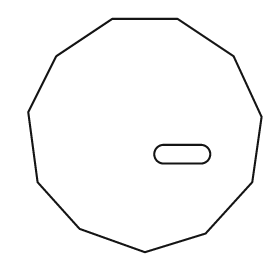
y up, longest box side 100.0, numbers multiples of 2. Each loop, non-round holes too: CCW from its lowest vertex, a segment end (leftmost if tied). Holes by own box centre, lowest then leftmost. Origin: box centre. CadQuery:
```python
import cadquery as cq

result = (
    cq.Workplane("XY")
    .moveTo(0.0, -50.0)
    .lineTo(26.0, -42.0)
    .lineTo(46.0, -20.0)
    .lineTo(50.0, 8.0)
    .lineTo(38.0, 34.0)
    .lineTo(14.0, 50.0)
    .lineTo(-14.0, 50.0)
    .lineTo(-38.0, 34.0)
    .lineTo(-50.0, 10.0)
    .lineTo(-46.0, -20.0)
    .lineTo(-28.0, -40.0)
    .close()
    .moveTo(8.0, -12.0)
    .lineTo(24.0, -12.0)
    .threePointArc((28.0, -8.0), (24.0, -4.0))
    .lineTo(8.0, -4.0)
    .threePointArc((4.0, -8.0), (8.0, -12.0))
    .close()
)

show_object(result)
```